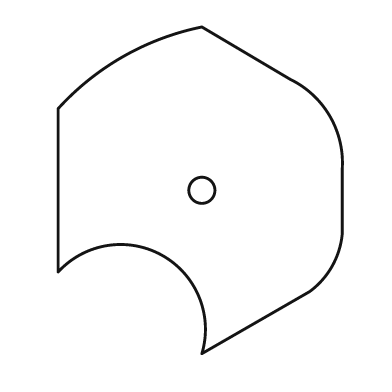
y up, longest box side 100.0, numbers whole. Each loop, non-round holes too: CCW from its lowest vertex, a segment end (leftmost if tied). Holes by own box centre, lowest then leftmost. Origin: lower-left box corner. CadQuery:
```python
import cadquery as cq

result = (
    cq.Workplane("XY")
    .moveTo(44.0, 0.0)
    .lineTo(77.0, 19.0)
    .threePointArc((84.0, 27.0), (87.0, 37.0))
    .lineTo(87.0, 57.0)
    .threePointArc((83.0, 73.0), (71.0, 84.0))
    .lineTo(44.0, 100.0)
    .threePointArc((20.0, 91.0), (0.0, 75.0))
    .lineTo(0.0, 25.0)
    .threePointArc((32.0, 30.0), (44.0, 0.0))
    .close()
    .moveTo(44.0, 50.0)
    .circle(4.0)
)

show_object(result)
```